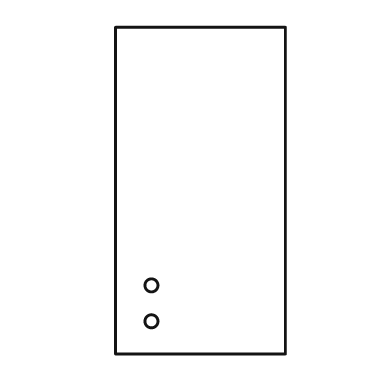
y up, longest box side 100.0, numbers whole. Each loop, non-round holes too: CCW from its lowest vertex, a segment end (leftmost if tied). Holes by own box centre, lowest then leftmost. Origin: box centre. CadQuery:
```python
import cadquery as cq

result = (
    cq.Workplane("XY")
    .moveTo(-26.0, -50.0)
    .lineTo(26.0, -50.0)
    .lineTo(26.0, 50.0)
    .lineTo(-26.0, 50.0)
    .close()
    .moveTo(-15.0, -40.0)
    .circle(2.0)
    .moveTo(-15.0, -29.0)
    .circle(2.0)
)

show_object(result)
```